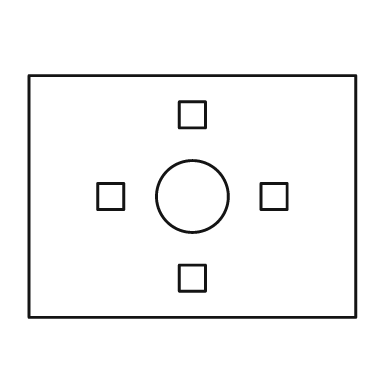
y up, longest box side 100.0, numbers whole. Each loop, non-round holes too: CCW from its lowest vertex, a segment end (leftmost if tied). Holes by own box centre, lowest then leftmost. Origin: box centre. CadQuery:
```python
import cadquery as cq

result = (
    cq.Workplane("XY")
    .moveTo(-50.0, -37.0)
    .lineTo(50.0, -37.0)
    .lineTo(50.0, 37.0)
    .lineTo(-50.0, 37.0)
    .close()
    .moveTo(-4.0, -29.0)
    .lineTo(4.0, -29.0)
    .lineTo(4.0, -21.0)
    .lineTo(-4.0, -21.0)
    .close()
    .moveTo(-29.0, -4.0)
    .lineTo(-21.0, -4.0)
    .lineTo(-21.0, 4.0)
    .lineTo(-29.0, 4.0)
    .close()
    .moveTo(0.0, 0.0)
    .circle(11.0)
    .moveTo(21.0, -4.0)
    .lineTo(29.0, -4.0)
    .lineTo(29.0, 4.0)
    .lineTo(21.0, 4.0)
    .close()
    .moveTo(-4.0, 21.0)
    .lineTo(4.0, 21.0)
    .lineTo(4.0, 29.0)
    .lineTo(-4.0, 29.0)
    .close()
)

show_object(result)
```